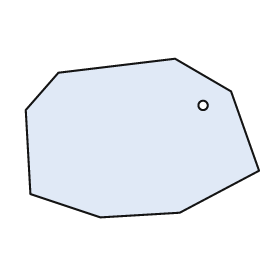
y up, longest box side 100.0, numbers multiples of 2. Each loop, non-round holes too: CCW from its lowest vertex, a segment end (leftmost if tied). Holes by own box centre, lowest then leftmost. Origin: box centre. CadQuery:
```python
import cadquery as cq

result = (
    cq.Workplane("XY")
    .moveTo(-18.0, -34.0)
    .lineTo(16.0, -32.0)
    .lineTo(50.0, -14.0)
    .lineTo(38.0, 20.0)
    .lineTo(14.0, 34.0)
    .lineTo(-36.0, 28.0)
    .lineTo(-50.0, 12.0)
    .lineTo(-48.0, -24.0)
    .close()
    .moveTo(26.0, 14.0)
    .circle(2.0)
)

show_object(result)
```